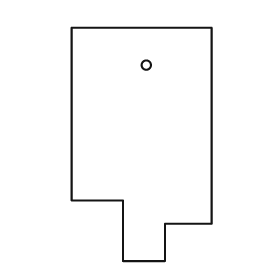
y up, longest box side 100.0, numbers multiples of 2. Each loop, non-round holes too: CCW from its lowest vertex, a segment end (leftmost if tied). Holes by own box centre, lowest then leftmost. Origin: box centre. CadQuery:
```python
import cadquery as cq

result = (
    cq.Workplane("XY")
    .moveTo(-8.0, -50.0)
    .lineTo(10.0, -50.0)
    .lineTo(10.0, -34.0)
    .lineTo(30.0, -34.0)
    .lineTo(30.0, 50.0)
    .lineTo(-30.0, 50.0)
    .lineTo(-30.0, -24.0)
    .lineTo(-8.0, -24.0)
    .close()
    .moveTo(2.0, 34.0)
    .circle(2.0)
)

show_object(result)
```